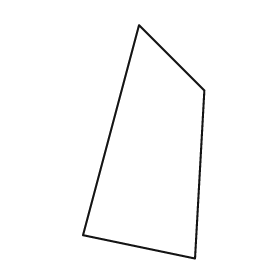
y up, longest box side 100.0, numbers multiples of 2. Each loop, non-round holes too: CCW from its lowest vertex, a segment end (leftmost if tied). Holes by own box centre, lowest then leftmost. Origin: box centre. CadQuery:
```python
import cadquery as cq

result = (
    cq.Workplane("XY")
    .moveTo(22.0, -50.0)
    .lineTo(26.0, 22.0)
    .lineTo(-2.0, 50.0)
    .lineTo(-26.0, -40.0)
    .close()
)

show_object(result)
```